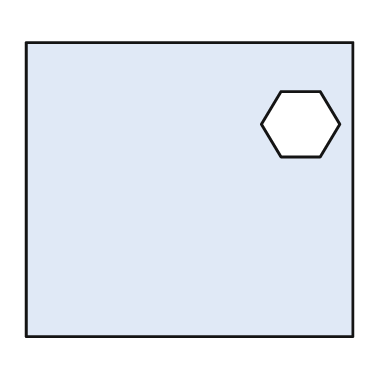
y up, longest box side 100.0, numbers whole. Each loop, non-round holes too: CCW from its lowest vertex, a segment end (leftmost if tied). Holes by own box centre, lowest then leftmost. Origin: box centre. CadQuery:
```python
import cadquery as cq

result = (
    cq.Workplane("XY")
    .moveTo(-50.0, -45.0)
    .lineTo(50.0, -45.0)
    .lineTo(50.0, 45.0)
    .lineTo(-50.0, 45.0)
    .close()
    .moveTo(28.0, 10.0)
    .lineTo(40.0, 10.0)
    .lineTo(46.0, 20.0)
    .lineTo(40.0, 30.0)
    .lineTo(28.0, 30.0)
    .lineTo(22.0, 20.0)
    .close()
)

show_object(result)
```